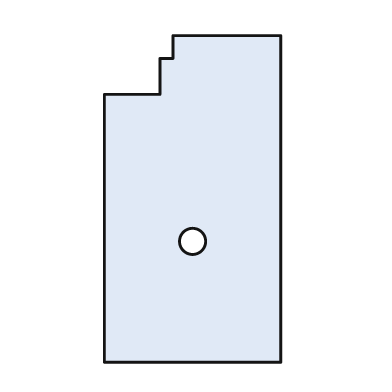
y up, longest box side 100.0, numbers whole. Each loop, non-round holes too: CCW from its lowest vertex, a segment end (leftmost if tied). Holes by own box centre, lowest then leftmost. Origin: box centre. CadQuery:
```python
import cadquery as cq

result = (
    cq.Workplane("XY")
    .moveTo(-27.0, -50.0)
    .lineTo(27.0, -50.0)
    .lineTo(27.0, 50.0)
    .lineTo(-6.0, 50.0)
    .lineTo(-6.0, 43.0)
    .lineTo(-10.0, 43.0)
    .lineTo(-10.0, 32.0)
    .lineTo(-27.0, 32.0)
    .close()
    .moveTo(0.0, -13.0)
    .circle(4.0)
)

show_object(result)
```